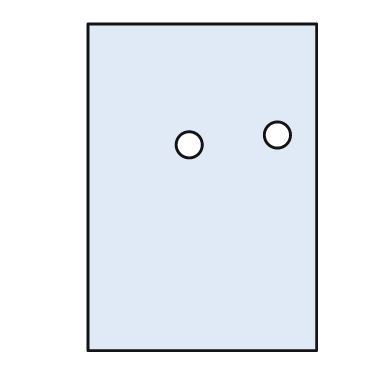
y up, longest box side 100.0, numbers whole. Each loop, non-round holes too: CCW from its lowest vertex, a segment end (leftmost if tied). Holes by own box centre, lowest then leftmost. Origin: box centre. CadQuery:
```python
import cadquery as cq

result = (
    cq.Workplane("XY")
    .moveTo(-35.0, -50.0)
    .lineTo(35.0, -50.0)
    .lineTo(35.0, 50.0)
    .lineTo(-35.0, 50.0)
    .close()
    .moveTo(-4.0, 13.0)
    .circle(4.0)
    .moveTo(23.0, 16.0)
    .circle(4.0)
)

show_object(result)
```